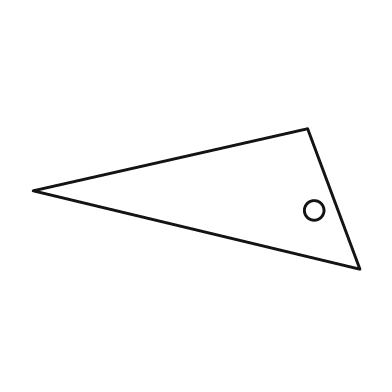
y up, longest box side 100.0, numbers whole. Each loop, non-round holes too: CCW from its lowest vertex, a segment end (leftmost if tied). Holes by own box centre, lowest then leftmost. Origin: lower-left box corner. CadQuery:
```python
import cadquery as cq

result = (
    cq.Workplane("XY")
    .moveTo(100.0, 0.0)
    .lineTo(84.0, 43.0)
    .lineTo(0.0, 24.0)
    .close()
    .moveTo(86.0, 18.0)
    .circle(3.0)
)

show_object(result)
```